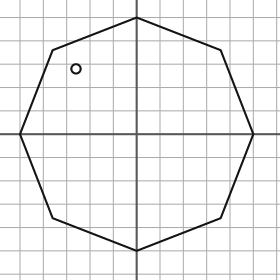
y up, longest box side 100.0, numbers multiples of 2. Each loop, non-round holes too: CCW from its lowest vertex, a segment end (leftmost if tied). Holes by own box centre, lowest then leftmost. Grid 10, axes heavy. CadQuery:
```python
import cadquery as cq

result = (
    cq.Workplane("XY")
    .moveTo(0.0, -50.0)
    .lineTo(36.0, -36.0)
    .lineTo(50.0, 0.0)
    .lineTo(36.0, 36.0)
    .lineTo(0.0, 50.0)
    .lineTo(-36.0, 36.0)
    .lineTo(-50.0, 0.0)
    .lineTo(-36.0, -36.0)
    .close()
    .moveTo(-26.0, 28.0)
    .circle(2.0)
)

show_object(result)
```